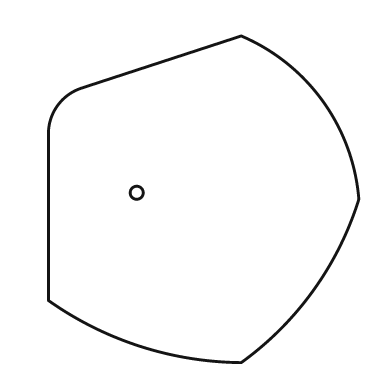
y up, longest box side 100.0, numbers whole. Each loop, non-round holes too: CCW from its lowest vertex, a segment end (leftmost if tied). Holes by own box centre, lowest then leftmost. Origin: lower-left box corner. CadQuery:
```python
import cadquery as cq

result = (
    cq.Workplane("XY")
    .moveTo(59.0, 0.0)
    .threePointArc((81.0, 22.0), (95.0, 50.0))
    .threePointArc((84.0, 80.0), (59.0, 100.0))
    .lineTo(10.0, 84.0)
    .threePointArc((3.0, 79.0), (0.0, 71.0))
    .lineTo(0.0, 19.0)
    .threePointArc((28.0, 5.0), (59.0, 0.0))
    .close()
    .moveTo(27.0, 52.0)
    .circle(2.0)
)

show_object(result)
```